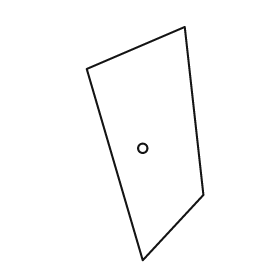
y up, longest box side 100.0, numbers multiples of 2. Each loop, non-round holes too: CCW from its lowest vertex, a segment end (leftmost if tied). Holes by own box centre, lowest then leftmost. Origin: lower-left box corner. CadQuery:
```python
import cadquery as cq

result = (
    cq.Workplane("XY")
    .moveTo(24.0, 0.0)
    .lineTo(50.0, 28.0)
    .lineTo(42.0, 100.0)
    .lineTo(0.0, 82.0)
    .close()
    .moveTo(24.0, 48.0)
    .circle(2.0)
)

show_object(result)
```